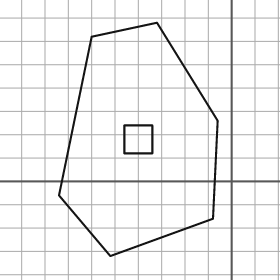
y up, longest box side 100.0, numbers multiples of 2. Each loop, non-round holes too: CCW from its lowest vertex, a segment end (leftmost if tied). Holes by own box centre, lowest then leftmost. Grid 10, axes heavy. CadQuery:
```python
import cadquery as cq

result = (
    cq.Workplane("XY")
    .moveTo(-52.0, -32.0)
    .lineTo(-8.0, -16.0)
    .lineTo(-6.0, 26.0)
    .lineTo(-32.0, 68.0)
    .lineTo(-60.0, 62.0)
    .lineTo(-74.0, -6.0)
    .close()
    .moveTo(-46.0, 12.0)
    .lineTo(-34.0, 12.0)
    .lineTo(-34.0, 24.0)
    .lineTo(-46.0, 24.0)
    .close()
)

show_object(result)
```